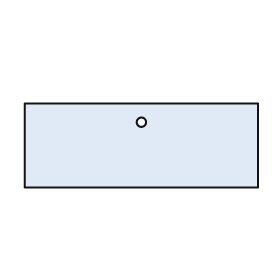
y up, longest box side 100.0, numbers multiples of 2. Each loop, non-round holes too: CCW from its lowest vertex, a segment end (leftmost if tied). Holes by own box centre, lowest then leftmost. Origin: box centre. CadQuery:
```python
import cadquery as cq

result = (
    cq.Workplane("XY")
    .moveTo(-50.0, -18.0)
    .lineTo(50.0, -18.0)
    .lineTo(50.0, 18.0)
    .lineTo(-50.0, 18.0)
    .close()
    .moveTo(0.0, 10.0)
    .circle(2.0)
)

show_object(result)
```